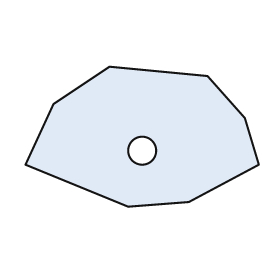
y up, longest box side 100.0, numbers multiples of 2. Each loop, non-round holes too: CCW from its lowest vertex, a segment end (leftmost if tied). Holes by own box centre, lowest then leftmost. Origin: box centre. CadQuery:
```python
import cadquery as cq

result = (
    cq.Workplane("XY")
    .moveTo(-6.0, -30.0)
    .lineTo(20.0, -28.0)
    .lineTo(50.0, -12.0)
    .lineTo(44.0, 8.0)
    .lineTo(28.0, 26.0)
    .lineTo(-14.0, 30.0)
    .lineTo(-38.0, 14.0)
    .lineTo(-50.0, -12.0)
    .close()
    .moveTo(0.0, -6.0)
    .circle(6.0)
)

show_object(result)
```